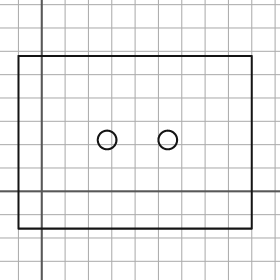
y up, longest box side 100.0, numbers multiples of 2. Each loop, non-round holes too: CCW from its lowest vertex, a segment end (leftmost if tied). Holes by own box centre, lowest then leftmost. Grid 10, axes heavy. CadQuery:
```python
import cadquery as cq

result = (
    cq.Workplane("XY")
    .moveTo(-10.0, -16.0)
    .lineTo(90.0, -16.0)
    .lineTo(90.0, 58.0)
    .lineTo(-10.0, 58.0)
    .close()
    .moveTo(28.0, 22.0)
    .circle(4.0)
    .moveTo(54.0, 22.0)
    .circle(4.0)
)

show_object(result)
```